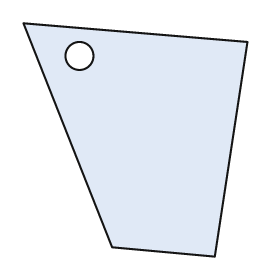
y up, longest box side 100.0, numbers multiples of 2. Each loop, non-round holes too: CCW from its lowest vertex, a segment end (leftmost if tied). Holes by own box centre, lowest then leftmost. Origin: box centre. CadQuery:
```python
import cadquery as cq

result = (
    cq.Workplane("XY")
    .moveTo(34.0, -50.0)
    .lineTo(48.0, 42.0)
    .lineTo(-48.0, 50.0)
    .lineTo(-10.0, -46.0)
    .close()
    .moveTo(-24.0, 36.0)
    .circle(6.0)
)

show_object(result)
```